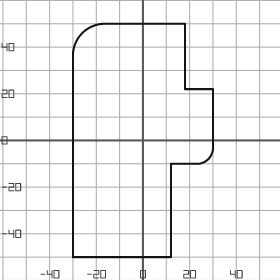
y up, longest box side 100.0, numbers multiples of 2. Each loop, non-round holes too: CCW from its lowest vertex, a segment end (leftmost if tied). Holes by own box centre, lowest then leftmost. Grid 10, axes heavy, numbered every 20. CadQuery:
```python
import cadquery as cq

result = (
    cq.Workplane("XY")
    .moveTo(-30.0, -50.0)
    .lineTo(12.0, -50.0)
    .lineTo(12.0, -10.0)
    .lineTo(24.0, -10.0)
    .threePointArc((28.0, -8.0), (30.0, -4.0))
    .lineTo(30.0, 22.0)
    .lineTo(18.0, 22.0)
    .lineTo(18.0, 50.0)
    .lineTo(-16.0, 50.0)
    .threePointArc((-26.0, 46.0), (-30.0, 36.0))
    .close()
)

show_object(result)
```